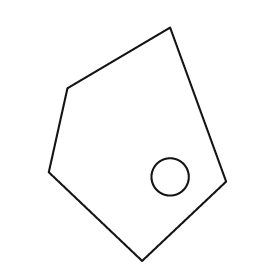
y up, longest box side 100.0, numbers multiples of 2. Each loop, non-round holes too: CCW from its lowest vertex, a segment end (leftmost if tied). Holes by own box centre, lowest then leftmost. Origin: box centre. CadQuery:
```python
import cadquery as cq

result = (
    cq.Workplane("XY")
    .moveTo(2.0, -50.0)
    .lineTo(38.0, -16.0)
    .lineTo(14.0, 50.0)
    .lineTo(-30.0, 24.0)
    .lineTo(-38.0, -12.0)
    .close()
    .moveTo(14.0, -14.0)
    .circle(8.0)
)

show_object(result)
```